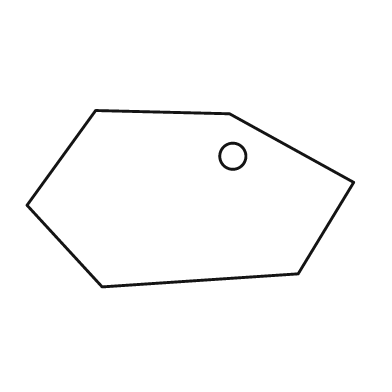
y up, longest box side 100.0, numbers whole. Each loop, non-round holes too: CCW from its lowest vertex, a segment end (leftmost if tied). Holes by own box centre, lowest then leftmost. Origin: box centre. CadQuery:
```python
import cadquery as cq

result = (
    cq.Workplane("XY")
    .moveTo(-27.0, -27.0)
    .lineTo(33.0, -23.0)
    .lineTo(50.0, 5.0)
    .lineTo(12.0, 26.0)
    .lineTo(-29.0, 27.0)
    .lineTo(-50.0, -2.0)
    .close()
    .moveTo(13.0, 13.0)
    .circle(4.0)
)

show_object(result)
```